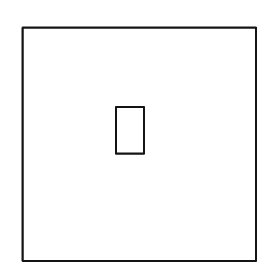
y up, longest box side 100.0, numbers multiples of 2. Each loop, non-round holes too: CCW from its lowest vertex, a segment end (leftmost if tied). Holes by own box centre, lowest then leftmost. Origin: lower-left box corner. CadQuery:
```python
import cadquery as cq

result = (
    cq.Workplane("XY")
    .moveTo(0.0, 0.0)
    .lineTo(100.0, 0.0)
    .lineTo(100.0, 100.0)
    .lineTo(0.0, 100.0)
    .close()
    .moveTo(40.0, 46.0)
    .lineTo(52.0, 46.0)
    .lineTo(52.0, 66.0)
    .lineTo(40.0, 66.0)
    .close()
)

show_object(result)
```